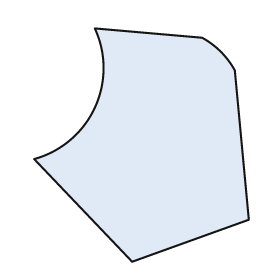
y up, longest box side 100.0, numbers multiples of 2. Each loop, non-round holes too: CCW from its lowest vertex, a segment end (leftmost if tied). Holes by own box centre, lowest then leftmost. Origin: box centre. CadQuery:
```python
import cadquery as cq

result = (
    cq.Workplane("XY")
    .moveTo(-4.0, -50.0)
    .lineTo(46.0, -32.0)
    .lineTo(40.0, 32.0)
    .threePointArc((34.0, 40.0), (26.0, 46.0))
    .lineTo(-20.0, 50.0)
    .threePointArc((-20.0, 16.0), (-46.0, -6.0))
    .close()
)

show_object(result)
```